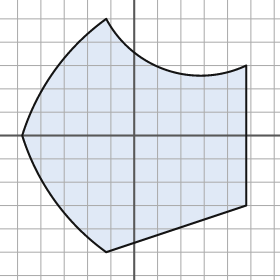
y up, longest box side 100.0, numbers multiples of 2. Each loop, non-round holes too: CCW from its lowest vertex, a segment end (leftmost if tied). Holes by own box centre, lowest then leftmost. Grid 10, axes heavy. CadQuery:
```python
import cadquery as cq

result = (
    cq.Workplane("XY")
    .moveTo(-12.0, -50.0)
    .lineTo(48.0, -30.0)
    .lineTo(48.0, 30.0)
    .threePointArc((14.0, 28.0), (-12.0, 50.0))
    .threePointArc((-34.0, 28.0), (-48.0, 0.0))
    .threePointArc((-34.0, -28.0), (-12.0, -50.0))
    .close()
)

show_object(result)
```